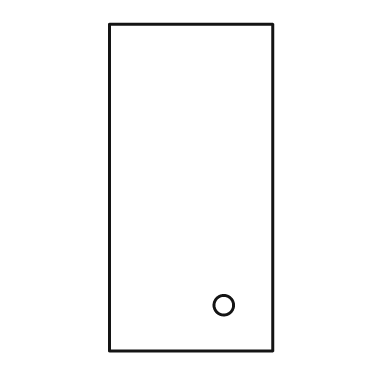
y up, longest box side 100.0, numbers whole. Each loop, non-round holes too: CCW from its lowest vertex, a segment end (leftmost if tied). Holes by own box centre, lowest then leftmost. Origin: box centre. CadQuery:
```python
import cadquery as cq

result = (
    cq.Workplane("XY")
    .moveTo(-25.0, -50.0)
    .lineTo(25.0, -50.0)
    .lineTo(25.0, 50.0)
    .lineTo(-25.0, 50.0)
    .close()
    .moveTo(10.0, -36.0)
    .circle(3.0)
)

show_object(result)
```